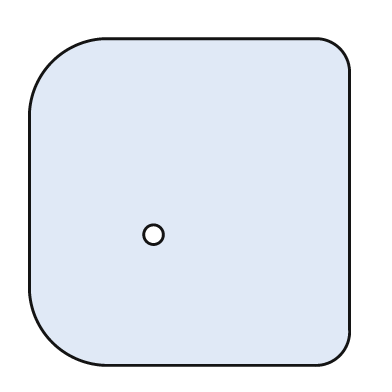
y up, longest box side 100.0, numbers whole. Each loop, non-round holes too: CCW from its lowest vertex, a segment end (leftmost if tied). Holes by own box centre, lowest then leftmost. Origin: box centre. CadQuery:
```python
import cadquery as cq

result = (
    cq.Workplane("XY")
    .moveTo(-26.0, -50.0)
    .lineTo(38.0, -50.0)
    .threePointArc((46.0, -47.0), (49.0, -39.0))
    .lineTo(49.0, 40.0)
    .threePointArc((46.0, 47.0), (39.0, 50.0))
    .lineTo(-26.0, 50.0)
    .threePointArc((-42.0, 43.0), (-49.0, 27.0))
    .lineTo(-49.0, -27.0)
    .threePointArc((-42.0, -43.0), (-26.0, -50.0))
    .close()
    .moveTo(-11.0, -10.0)
    .circle(3.0)
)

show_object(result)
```